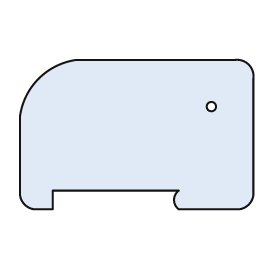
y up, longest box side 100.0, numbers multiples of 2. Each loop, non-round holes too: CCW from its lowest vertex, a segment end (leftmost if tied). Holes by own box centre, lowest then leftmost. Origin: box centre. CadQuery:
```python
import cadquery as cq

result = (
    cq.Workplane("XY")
    .moveTo(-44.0, -32.0)
    .lineTo(-36.0, -32.0)
    .lineTo(-36.0, -24.0)
    .lineTo(18.0, -24.0)
    .threePointArc((16.0, -28.0), (18.0, -32.0))
    .lineTo(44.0, -32.0)
    .threePointArc((48.0, -30.0), (50.0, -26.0))
    .lineTo(50.0, 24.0)
    .threePointArc((48.0, 30.0), (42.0, 32.0))
    .lineTo(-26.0, 32.0)
    .threePointArc((-42.0, 24.0), (-50.0, 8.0))
    .lineTo(-50.0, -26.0)
    .threePointArc((-48.0, -30.0), (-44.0, -32.0))
    .close()
    .moveTo(32.0, 12.0)
    .circle(2.0)
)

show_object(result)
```